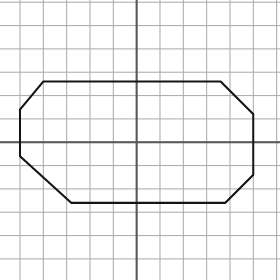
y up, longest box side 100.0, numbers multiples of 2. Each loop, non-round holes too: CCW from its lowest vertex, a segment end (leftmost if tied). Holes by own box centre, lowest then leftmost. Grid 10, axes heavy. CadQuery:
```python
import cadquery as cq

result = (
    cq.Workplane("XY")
    .moveTo(-28.0, -26.0)
    .lineTo(38.0, -26.0)
    .lineTo(50.0, -14.0)
    .lineTo(50.0, 12.0)
    .lineTo(36.0, 26.0)
    .lineTo(-40.0, 26.0)
    .lineTo(-50.0, 14.0)
    .lineTo(-50.0, -6.0)
    .close()
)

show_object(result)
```